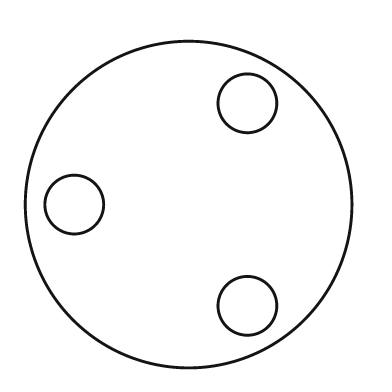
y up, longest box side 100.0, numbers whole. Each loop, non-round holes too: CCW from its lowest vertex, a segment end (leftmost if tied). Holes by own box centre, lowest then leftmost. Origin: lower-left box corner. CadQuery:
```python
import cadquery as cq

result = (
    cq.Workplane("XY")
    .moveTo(50.0, 50.0)
    .circle(50.0)
    .moveTo(68.0, 19.0)
    .circle(9.0)
    .moveTo(15.0, 50.0)
    .circle(9.0)
    .moveTo(68.0, 81.0)
    .circle(9.0)
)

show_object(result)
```